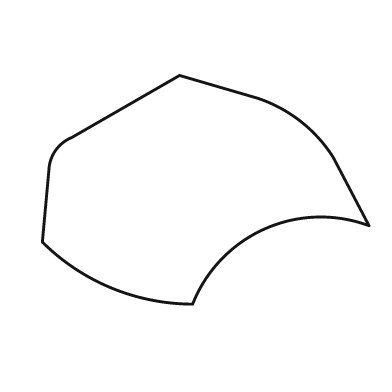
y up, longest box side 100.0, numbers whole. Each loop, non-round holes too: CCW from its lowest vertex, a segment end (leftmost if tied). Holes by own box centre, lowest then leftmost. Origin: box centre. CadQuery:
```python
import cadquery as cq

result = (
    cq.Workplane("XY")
    .moveTo(-4.0, -35.0)
    .threePointArc((18.0, -12.0), (50.0, -11.0))
    .lineTo(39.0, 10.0)
    .threePointArc((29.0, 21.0), (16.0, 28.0))
    .lineTo(-8.0, 35.0)
    .lineTo(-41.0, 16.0)
    .threePointArc((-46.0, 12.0), (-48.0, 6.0))
    .lineTo(-50.0, -16.0)
    .threePointArc((-29.0, -30.0), (-4.0, -35.0))
    .close()
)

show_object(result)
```